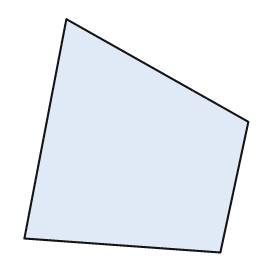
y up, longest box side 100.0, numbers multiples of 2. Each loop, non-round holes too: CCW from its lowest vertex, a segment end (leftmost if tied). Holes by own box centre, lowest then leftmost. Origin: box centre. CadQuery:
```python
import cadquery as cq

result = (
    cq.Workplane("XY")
    .moveTo(36.0, -50.0)
    .lineTo(48.0, 6.0)
    .lineTo(-30.0, 50.0)
    .lineTo(-48.0, -44.0)
    .close()
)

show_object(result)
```